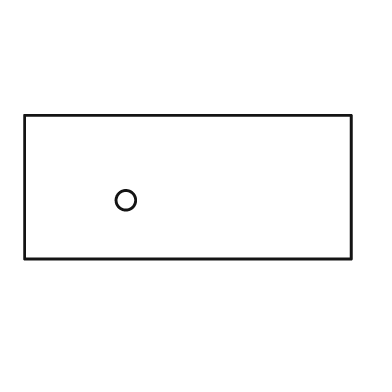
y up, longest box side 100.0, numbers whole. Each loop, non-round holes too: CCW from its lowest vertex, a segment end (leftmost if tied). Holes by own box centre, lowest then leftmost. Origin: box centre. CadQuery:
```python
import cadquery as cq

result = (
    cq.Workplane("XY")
    .moveTo(-50.0, -22.0)
    .lineTo(50.0, -22.0)
    .lineTo(50.0, 22.0)
    .lineTo(-50.0, 22.0)
    .close()
    .moveTo(-19.0, -4.0)
    .circle(3.0)
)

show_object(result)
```